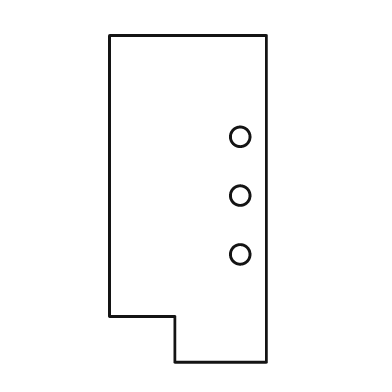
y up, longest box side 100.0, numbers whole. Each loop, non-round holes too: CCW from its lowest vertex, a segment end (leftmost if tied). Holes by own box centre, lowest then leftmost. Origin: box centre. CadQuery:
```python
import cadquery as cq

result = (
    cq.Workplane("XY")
    .moveTo(-4.0, -50.0)
    .lineTo(24.0, -50.0)
    .lineTo(24.0, 50.0)
    .lineTo(-24.0, 50.0)
    .lineTo(-24.0, -36.0)
    .lineTo(-4.0, -36.0)
    .close()
    .moveTo(16.0, -17.0)
    .circle(3.0)
    .moveTo(16.0, 1.0)
    .circle(3.0)
    .moveTo(16.0, 19.0)
    .circle(3.0)
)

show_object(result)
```